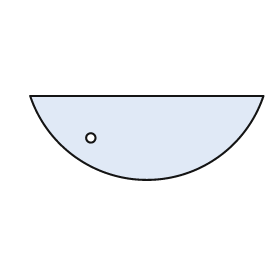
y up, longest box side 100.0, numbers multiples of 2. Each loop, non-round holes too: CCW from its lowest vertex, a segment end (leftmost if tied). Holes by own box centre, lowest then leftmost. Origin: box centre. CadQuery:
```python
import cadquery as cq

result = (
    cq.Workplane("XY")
    .moveTo(-50.0, 18.0)
    .threePointArc((0.0, -18.0), (50.0, 18.0))
    .close()
    .moveTo(-24.0, 0.0)
    .circle(2.0)
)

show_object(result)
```